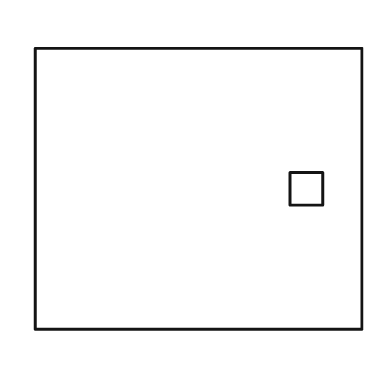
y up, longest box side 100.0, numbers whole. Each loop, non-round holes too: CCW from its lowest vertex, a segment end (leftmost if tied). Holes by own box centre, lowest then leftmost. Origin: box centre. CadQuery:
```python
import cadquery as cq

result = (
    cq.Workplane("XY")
    .moveTo(-50.0, -43.0)
    .lineTo(50.0, -43.0)
    .lineTo(50.0, 43.0)
    .lineTo(-50.0, 43.0)
    .close()
    .moveTo(28.0, -5.0)
    .lineTo(38.0, -5.0)
    .lineTo(38.0, 5.0)
    .lineTo(28.0, 5.0)
    .close()
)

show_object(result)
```